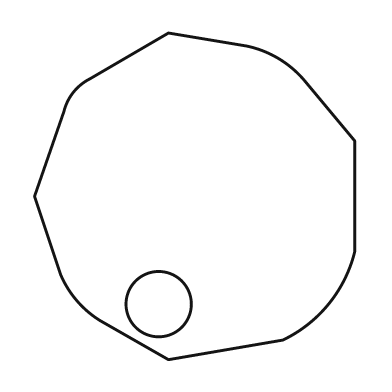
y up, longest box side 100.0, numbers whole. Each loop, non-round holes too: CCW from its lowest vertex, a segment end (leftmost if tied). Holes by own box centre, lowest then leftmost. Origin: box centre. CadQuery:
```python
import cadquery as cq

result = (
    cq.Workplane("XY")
    .moveTo(-8.0, -50.0)
    .lineTo(27.0, -44.0)
    .threePointArc((41.0, -33.0), (49.0, -17.0))
    .lineTo(49.0, 17.0)
    .lineTo(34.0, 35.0)
    .threePointArc((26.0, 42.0), (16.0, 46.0))
    .lineTo(-8.0, 50.0)
    .lineTo(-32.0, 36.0)
    .threePointArc((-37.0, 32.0), (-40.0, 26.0))
    .lineTo(-49.0, 0.0)
    .lineTo(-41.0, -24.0)
    .threePointArc((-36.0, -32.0), (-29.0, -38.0))
    .close()
    .moveTo(-11.0, -33.0)
    .circle(10.0)
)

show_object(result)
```